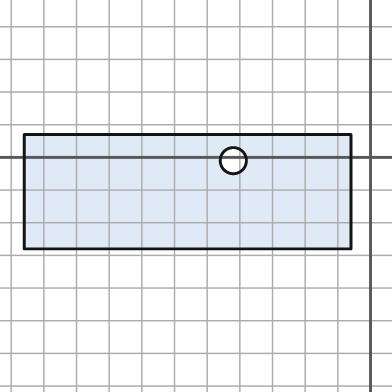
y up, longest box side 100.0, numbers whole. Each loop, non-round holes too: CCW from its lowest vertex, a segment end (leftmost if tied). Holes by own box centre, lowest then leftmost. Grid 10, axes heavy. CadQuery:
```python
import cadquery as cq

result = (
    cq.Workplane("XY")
    .moveTo(-106.0, -28.0)
    .lineTo(-6.0, -28.0)
    .lineTo(-6.0, 7.0)
    .lineTo(-106.0, 7.0)
    .close()
    .moveTo(-42.0, -1.0)
    .circle(4.0)
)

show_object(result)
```